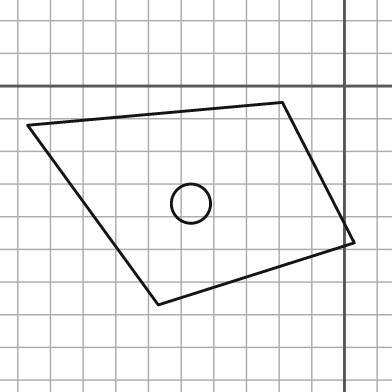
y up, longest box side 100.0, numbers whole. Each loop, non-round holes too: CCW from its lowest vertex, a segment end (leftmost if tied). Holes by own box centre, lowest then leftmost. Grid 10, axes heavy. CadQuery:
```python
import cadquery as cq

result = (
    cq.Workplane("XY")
    .moveTo(-57.0, -67.0)
    .lineTo(3.0, -48.0)
    .lineTo(-19.0, -5.0)
    .lineTo(-97.0, -12.0)
    .close()
    .moveTo(-47.0, -36.0)
    .circle(6.0)
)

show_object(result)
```